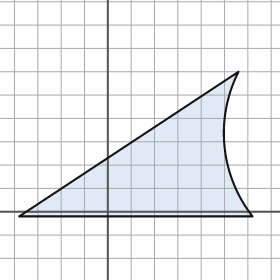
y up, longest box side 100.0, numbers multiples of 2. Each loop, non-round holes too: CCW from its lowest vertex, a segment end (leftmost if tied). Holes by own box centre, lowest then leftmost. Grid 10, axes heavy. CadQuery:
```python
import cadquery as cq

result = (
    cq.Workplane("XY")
    .moveTo(-38.0, -2.0)
    .lineTo(62.0, -2.0)
    .threePointArc((50.0, 28.0), (56.0, 60.0))
    .close()
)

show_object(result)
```